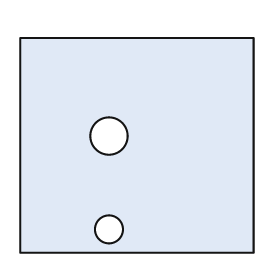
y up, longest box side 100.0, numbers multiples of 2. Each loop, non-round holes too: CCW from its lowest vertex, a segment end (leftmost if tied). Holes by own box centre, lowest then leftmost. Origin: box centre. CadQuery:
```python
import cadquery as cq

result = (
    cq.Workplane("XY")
    .moveTo(-50.0, -46.0)
    .lineTo(50.0, -46.0)
    .lineTo(50.0, 46.0)
    .lineTo(-50.0, 46.0)
    .close()
    .moveTo(-12.0, -36.0)
    .circle(6.0)
    .moveTo(-12.0, 4.0)
    .circle(8.0)
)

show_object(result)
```